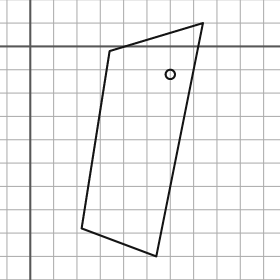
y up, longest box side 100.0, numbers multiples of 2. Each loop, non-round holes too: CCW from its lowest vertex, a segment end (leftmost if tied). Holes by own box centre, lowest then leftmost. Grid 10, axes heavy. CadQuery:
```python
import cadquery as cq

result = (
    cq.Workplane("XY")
    .moveTo(54.0, -90.0)
    .lineTo(74.0, 10.0)
    .lineTo(34.0, -2.0)
    .lineTo(22.0, -78.0)
    .close()
    .moveTo(60.0, -12.0)
    .circle(2.0)
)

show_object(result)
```